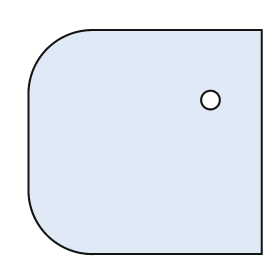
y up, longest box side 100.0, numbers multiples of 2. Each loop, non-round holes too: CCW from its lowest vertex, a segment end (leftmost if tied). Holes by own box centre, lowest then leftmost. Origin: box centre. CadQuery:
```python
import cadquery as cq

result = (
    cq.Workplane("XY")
    .moveTo(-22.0, -48.0)
    .lineTo(50.0, -48.0)
    .lineTo(50.0, 48.0)
    .lineTo(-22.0, 48.0)
    .threePointArc((-42.0, 40.0), (-50.0, 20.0))
    .lineTo(-50.0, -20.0)
    .threePointArc((-42.0, -40.0), (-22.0, -48.0))
    .close()
    .moveTo(28.0, 18.0)
    .circle(4.0)
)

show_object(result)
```